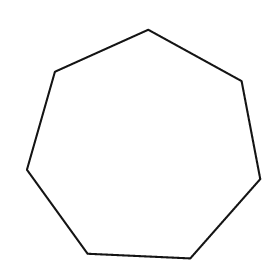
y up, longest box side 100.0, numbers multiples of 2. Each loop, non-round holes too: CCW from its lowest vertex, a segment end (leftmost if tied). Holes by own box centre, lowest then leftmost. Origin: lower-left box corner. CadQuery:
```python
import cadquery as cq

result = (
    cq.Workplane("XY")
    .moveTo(70.0, 0.0)
    .lineTo(100.0, 34.0)
    .lineTo(92.0, 76.0)
    .lineTo(52.0, 98.0)
    .lineTo(12.0, 80.0)
    .lineTo(0.0, 38.0)
    .lineTo(26.0, 2.0)
    .close()
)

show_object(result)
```